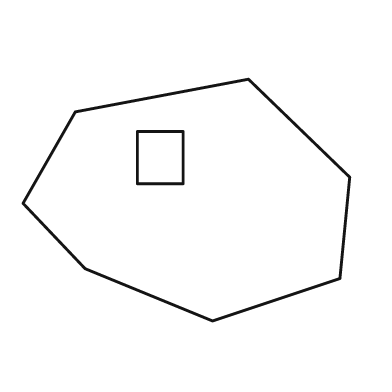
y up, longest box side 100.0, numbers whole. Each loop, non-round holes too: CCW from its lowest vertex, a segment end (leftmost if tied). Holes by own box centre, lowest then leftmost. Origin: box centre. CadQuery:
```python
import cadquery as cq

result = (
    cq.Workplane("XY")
    .moveTo(8.0, -37.0)
    .lineTo(47.0, -24.0)
    .lineTo(50.0, 7.0)
    .lineTo(19.0, 37.0)
    .lineTo(-34.0, 27.0)
    .lineTo(-50.0, -1.0)
    .lineTo(-31.0, -21.0)
    .close()
    .moveTo(-15.0, 5.0)
    .lineTo(-1.0, 5.0)
    .lineTo(-1.0, 21.0)
    .lineTo(-15.0, 21.0)
    .close()
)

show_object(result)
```